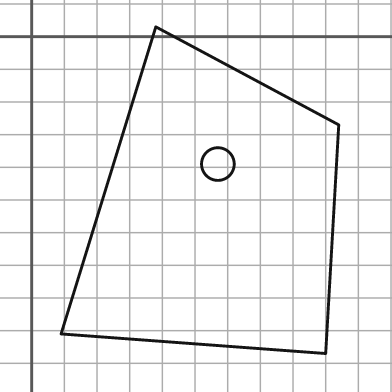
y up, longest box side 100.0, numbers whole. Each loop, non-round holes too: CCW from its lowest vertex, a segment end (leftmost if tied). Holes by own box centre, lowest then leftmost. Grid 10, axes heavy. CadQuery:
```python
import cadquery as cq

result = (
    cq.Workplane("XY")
    .moveTo(90.0, -97.0)
    .lineTo(94.0, -27.0)
    .lineTo(38.0, 3.0)
    .lineTo(9.0, -91.0)
    .close()
    .moveTo(57.0, -39.0)
    .circle(5.0)
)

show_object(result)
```